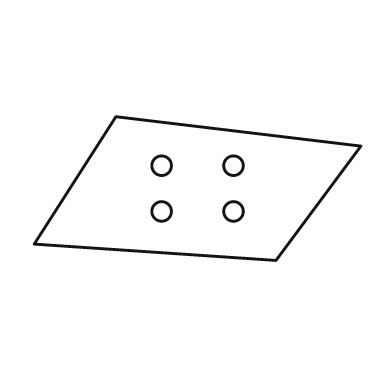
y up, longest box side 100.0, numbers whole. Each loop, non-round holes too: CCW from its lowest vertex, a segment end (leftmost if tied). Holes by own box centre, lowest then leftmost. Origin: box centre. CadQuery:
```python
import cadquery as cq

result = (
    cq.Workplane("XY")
    .moveTo(24.0, -22.0)
    .lineTo(50.0, 13.0)
    .lineTo(-25.0, 22.0)
    .lineTo(-50.0, -17.0)
    .close()
    .moveTo(-11.0, -7.0)
    .circle(3.0)
    .moveTo(11.0, -7.0)
    .circle(3.0)
    .moveTo(-11.0, 7.0)
    .circle(3.0)
    .moveTo(11.0, 7.0)
    .circle(3.0)
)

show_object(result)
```